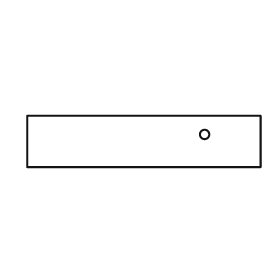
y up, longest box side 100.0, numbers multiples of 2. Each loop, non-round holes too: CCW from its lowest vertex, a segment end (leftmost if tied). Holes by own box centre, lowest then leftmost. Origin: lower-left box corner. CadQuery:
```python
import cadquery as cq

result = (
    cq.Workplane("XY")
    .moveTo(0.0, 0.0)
    .lineTo(100.0, 0.0)
    .lineTo(100.0, 22.0)
    .lineTo(0.0, 22.0)
    .close()
    .moveTo(76.0, 14.0)
    .circle(2.0)
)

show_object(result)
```